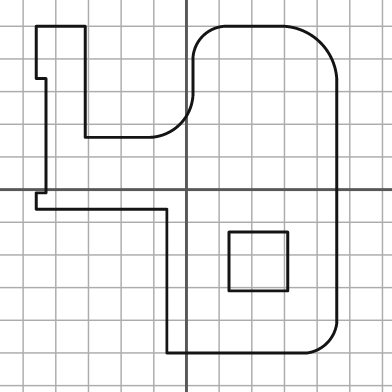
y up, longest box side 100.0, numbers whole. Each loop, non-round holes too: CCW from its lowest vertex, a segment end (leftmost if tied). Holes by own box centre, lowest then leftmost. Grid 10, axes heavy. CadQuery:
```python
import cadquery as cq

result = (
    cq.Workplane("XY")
    .moveTo(-6.0, -50.0)
    .lineTo(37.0, -50.0)
    .threePointArc((43.0, -47.0), (46.0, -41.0))
    .lineTo(46.0, 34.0)
    .threePointArc((41.0, 45.0), (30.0, 50.0))
    .lineTo(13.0, 50.0)
    .threePointArc((5.0, 47.0), (2.0, 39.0))
    .lineTo(2.0, 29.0)
    .threePointArc((-2.0, 20.0), (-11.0, 16.0))
    .lineTo(-31.0, 16.0)
    .lineTo(-31.0, 50.0)
    .lineTo(-46.0, 50.0)
    .lineTo(-46.0, 34.0)
    .lineTo(-43.0, 34.0)
    .lineTo(-43.0, -1.0)
    .lineTo(-46.0, -1.0)
    .lineTo(-46.0, -6.0)
    .lineTo(-6.0, -6.0)
    .close()
    .moveTo(13.0, -31.0)
    .lineTo(31.0, -31.0)
    .lineTo(31.0, -13.0)
    .lineTo(13.0, -13.0)
    .close()
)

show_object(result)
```